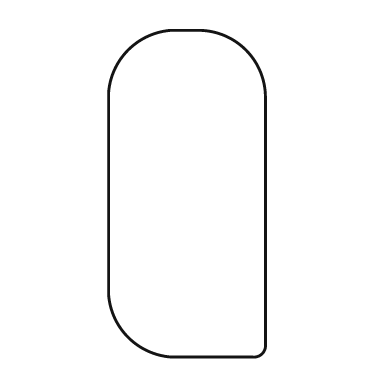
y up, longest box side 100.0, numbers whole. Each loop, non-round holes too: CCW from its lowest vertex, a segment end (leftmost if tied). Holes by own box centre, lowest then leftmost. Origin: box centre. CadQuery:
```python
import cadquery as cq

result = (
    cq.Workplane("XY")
    .moveTo(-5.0, -50.0)
    .lineTo(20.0, -50.0)
    .threePointArc((23.0, -49.0), (24.0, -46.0))
    .lineTo(24.0, 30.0)
    .threePointArc((18.0, 44.0), (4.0, 50.0))
    .lineTo(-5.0, 50.0)
    .threePointArc((-18.0, 44.0), (-24.0, 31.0))
    .lineTo(-24.0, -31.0)
    .threePointArc((-18.0, -44.0), (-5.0, -50.0))
    .close()
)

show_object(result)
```